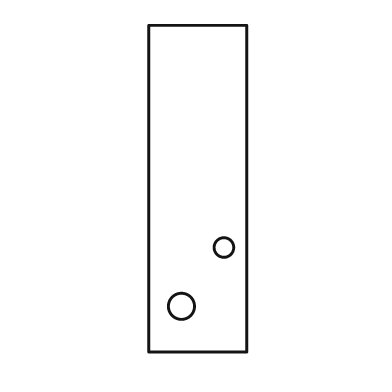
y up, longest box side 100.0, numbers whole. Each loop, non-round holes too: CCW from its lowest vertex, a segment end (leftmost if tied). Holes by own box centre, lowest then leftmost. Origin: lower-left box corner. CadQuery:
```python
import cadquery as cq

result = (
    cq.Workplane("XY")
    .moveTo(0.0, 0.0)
    .lineTo(30.0, 0.0)
    .lineTo(30.0, 100.0)
    .lineTo(0.0, 100.0)
    .close()
    .moveTo(10.0, 14.0)
    .circle(4.0)
    .moveTo(23.0, 32.0)
    .circle(3.0)
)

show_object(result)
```